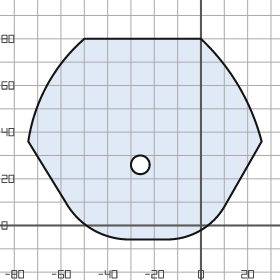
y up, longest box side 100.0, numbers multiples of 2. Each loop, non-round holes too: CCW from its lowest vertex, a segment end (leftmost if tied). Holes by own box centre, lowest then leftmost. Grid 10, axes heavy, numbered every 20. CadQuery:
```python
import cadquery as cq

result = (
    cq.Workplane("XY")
    .moveTo(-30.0, -6.0)
    .lineTo(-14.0, -6.0)
    .threePointArc((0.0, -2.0), (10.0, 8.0))
    .lineTo(26.0, 36.0)
    .threePointArc((16.0, 60.0), (0.0, 80.0))
    .lineTo(-50.0, 80.0)
    .threePointArc((-66.0, 60.0), (-74.0, 36.0))
    .lineTo(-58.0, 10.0)
    .threePointArc((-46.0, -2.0), (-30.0, -6.0))
    .close()
    .moveTo(-26.0, 26.0)
    .circle(4.0)
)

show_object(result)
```